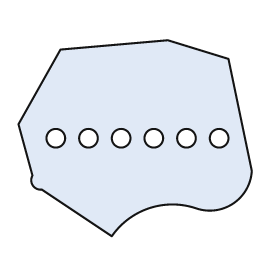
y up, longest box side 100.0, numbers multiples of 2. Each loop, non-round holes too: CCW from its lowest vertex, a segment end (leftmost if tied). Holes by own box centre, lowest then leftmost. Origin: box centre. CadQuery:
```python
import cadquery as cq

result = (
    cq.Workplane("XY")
    .moveTo(-10.0, -42.0)
    .threePointArc((6.0, -30.0), (26.0, -30.0))
    .threePointArc((42.0, -28.0), (50.0, -14.0))
    .lineTo(40.0, 34.0)
    .lineTo(14.0, 42.0)
    .lineTo(-32.0, 38.0)
    .lineTo(-50.0, 6.0)
    .lineTo(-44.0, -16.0)
    .threePointArc((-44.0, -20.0), (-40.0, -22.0))
    .close()
    .moveTo(-34.0, 0.0)
    .circle(4.0)
    .moveTo(-20.0, 0.0)
    .circle(4.0)
    .moveTo(-6.0, 0.0)
    .circle(4.0)
    .moveTo(8.0, 0.0)
    .circle(4.0)
    .moveTo(22.0, 0.0)
    .circle(4.0)
    .moveTo(36.0, 0.0)
    .circle(4.0)
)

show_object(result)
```